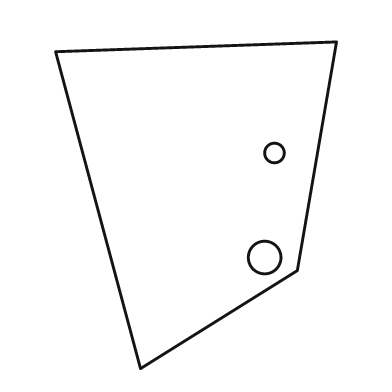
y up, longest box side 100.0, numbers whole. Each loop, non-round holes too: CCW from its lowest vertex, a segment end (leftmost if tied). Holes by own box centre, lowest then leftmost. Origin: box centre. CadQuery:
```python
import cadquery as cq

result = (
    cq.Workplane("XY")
    .moveTo(-17.0, -50.0)
    .lineTo(31.0, -20.0)
    .lineTo(43.0, 50.0)
    .lineTo(-43.0, 47.0)
    .close()
    .moveTo(21.0, -16.0)
    .circle(5.0)
    .moveTo(24.0, 16.0)
    .circle(3.0)
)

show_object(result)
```